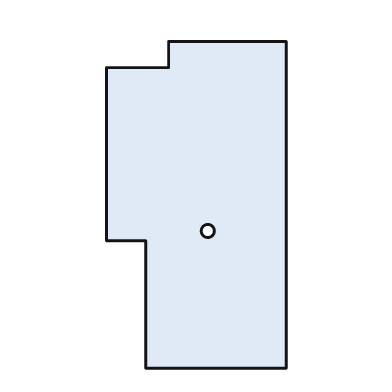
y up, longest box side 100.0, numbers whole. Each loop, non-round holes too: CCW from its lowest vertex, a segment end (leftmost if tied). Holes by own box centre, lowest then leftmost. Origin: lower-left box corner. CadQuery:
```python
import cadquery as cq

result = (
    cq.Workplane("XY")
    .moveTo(12.0, 0.0)
    .lineTo(55.0, 0.0)
    .lineTo(55.0, 100.0)
    .lineTo(19.0, 100.0)
    .lineTo(19.0, 92.0)
    .lineTo(0.0, 92.0)
    .lineTo(0.0, 39.0)
    .lineTo(12.0, 39.0)
    .close()
    .moveTo(31.0, 42.0)
    .circle(2.0)
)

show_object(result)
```